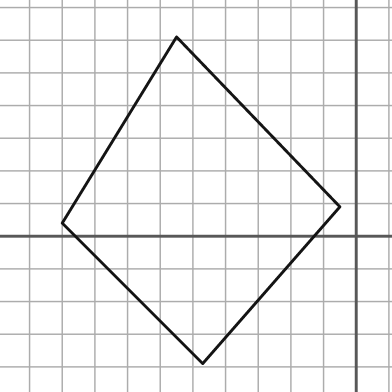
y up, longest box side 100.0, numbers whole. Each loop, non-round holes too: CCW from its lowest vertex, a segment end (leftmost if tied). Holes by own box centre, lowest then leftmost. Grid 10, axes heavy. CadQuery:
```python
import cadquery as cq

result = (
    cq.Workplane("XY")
    .moveTo(-47.0, -39.0)
    .lineTo(-5.0, 9.0)
    .lineTo(-55.0, 61.0)
    .lineTo(-90.0, 4.0)
    .close()
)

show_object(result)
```